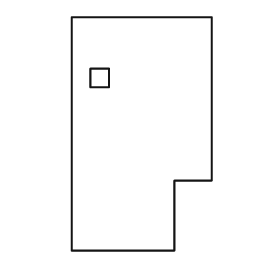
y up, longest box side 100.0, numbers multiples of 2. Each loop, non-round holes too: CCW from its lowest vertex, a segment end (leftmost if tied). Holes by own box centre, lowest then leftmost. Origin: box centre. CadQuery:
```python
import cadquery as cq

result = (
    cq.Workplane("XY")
    .moveTo(-30.0, -50.0)
    .lineTo(14.0, -50.0)
    .lineTo(14.0, -20.0)
    .lineTo(30.0, -20.0)
    .lineTo(30.0, 50.0)
    .lineTo(-30.0, 50.0)
    .close()
    .moveTo(-22.0, 20.0)
    .lineTo(-14.0, 20.0)
    .lineTo(-14.0, 28.0)
    .lineTo(-22.0, 28.0)
    .close()
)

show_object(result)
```